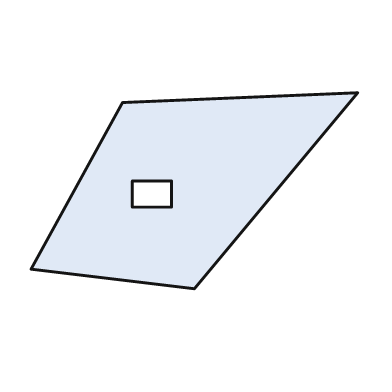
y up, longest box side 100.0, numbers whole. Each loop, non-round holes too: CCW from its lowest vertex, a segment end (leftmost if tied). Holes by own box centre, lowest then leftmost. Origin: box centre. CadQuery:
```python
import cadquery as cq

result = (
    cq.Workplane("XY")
    .moveTo(0.0, -30.0)
    .lineTo(50.0, 30.0)
    .lineTo(-22.0, 27.0)
    .lineTo(-50.0, -24.0)
    .close()
    .moveTo(-19.0, -5.0)
    .lineTo(-7.0, -5.0)
    .lineTo(-7.0, 3.0)
    .lineTo(-19.0, 3.0)
    .close()
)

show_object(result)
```